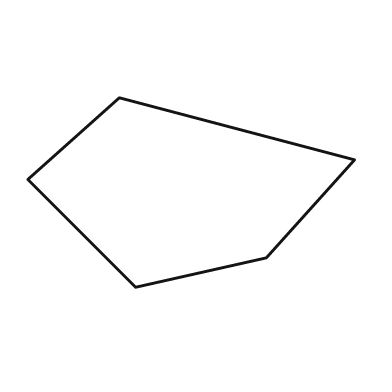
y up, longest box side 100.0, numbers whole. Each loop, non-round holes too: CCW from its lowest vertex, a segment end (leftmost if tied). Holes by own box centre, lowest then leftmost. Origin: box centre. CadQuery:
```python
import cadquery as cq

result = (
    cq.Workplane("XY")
    .moveTo(-17.0, -29.0)
    .lineTo(23.0, -20.0)
    .lineTo(50.0, 10.0)
    .lineTo(-22.0, 29.0)
    .lineTo(-50.0, 4.0)
    .close()
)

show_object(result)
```